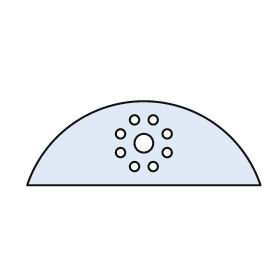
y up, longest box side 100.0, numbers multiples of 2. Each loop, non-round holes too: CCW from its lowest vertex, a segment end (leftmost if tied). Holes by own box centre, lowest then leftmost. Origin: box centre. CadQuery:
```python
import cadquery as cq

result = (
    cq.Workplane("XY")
    .moveTo(-50.0, -18.0)
    .lineTo(50.0, -18.0)
    .threePointArc((0.0, 18.0), (-50.0, -18.0))
    .close()
    .moveTo(-4.0, -10.0)
    .circle(2.0)
    .moveTo(4.0, -10.0)
    .circle(2.0)
    .moveTo(-10.0, -4.0)
    .circle(2.0)
    .moveTo(10.0, -4.0)
    .circle(2.0)
    .moveTo(0.0, 0.0)
    .circle(4.0)
    .moveTo(-10.0, 4.0)
    .circle(2.0)
    .moveTo(10.0, 4.0)
    .circle(2.0)
    .moveTo(-4.0, 10.0)
    .circle(2.0)
    .moveTo(4.0, 10.0)
    .circle(2.0)
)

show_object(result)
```